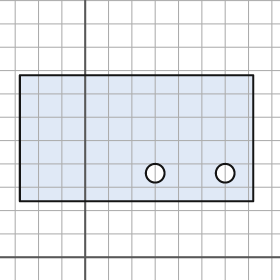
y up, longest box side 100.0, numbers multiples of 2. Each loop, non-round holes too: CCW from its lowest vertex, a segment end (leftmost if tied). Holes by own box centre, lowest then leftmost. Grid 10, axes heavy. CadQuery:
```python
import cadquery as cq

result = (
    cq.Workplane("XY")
    .moveTo(-28.0, 24.0)
    .lineTo(72.0, 24.0)
    .lineTo(72.0, 78.0)
    .lineTo(-28.0, 78.0)
    .close()
    .moveTo(30.0, 36.0)
    .circle(4.0)
    .moveTo(60.0, 36.0)
    .circle(4.0)
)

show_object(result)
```